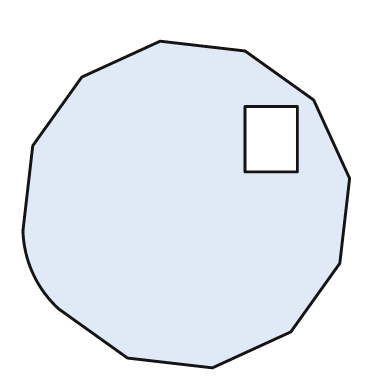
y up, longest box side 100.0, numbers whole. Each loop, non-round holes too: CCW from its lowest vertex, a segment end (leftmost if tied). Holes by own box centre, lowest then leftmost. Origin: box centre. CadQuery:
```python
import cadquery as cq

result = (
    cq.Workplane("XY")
    .moveTo(8.0, -50.0)
    .lineTo(32.0, -39.0)
    .lineTo(47.0, -18.0)
    .lineTo(50.0, 8.0)
    .lineTo(39.0, 32.0)
    .lineTo(18.0, 47.0)
    .lineTo(-8.0, 50.0)
    .lineTo(-32.0, 39.0)
    .lineTo(-47.0, 18.0)
    .lineTo(-50.0, -8.0)
    .threePointArc((-47.0, -21.0), (-39.0, -32.0))
    .lineTo(-18.0, -47.0)
    .close()
    .moveTo(18.0, 10.0)
    .lineTo(34.0, 10.0)
    .lineTo(34.0, 30.0)
    .lineTo(18.0, 30.0)
    .close()
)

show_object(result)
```